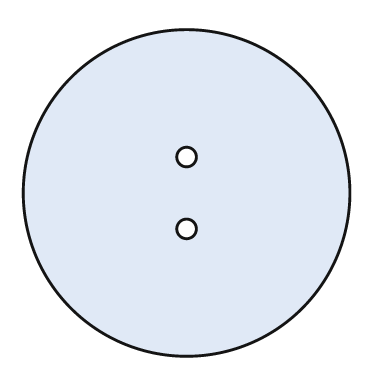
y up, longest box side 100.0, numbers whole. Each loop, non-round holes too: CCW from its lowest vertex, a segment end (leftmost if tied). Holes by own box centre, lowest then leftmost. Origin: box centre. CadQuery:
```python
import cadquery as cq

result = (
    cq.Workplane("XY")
    .moveTo(0.0, 0.0)
    .circle(50.0)
    .moveTo(0.0, -11.0)
    .circle(3.0)
    .moveTo(0.0, 11.0)
    .circle(3.0)
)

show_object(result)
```